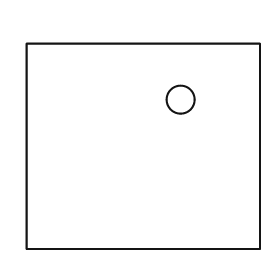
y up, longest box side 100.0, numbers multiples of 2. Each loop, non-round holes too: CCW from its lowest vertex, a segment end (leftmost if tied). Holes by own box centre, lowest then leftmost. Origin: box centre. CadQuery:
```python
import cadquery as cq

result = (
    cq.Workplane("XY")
    .moveTo(-50.0, -44.0)
    .lineTo(50.0, -44.0)
    .lineTo(50.0, 44.0)
    .lineTo(-50.0, 44.0)
    .close()
    .moveTo(16.0, 20.0)
    .circle(6.0)
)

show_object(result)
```